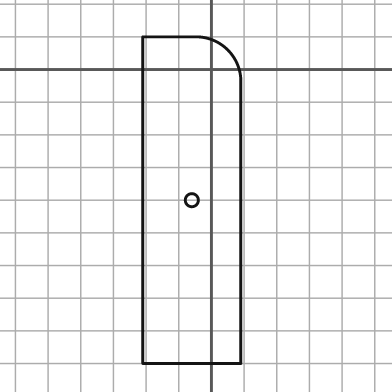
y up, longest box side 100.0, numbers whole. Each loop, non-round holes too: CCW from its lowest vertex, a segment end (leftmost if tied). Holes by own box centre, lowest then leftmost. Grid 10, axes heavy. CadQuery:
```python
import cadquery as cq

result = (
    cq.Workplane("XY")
    .moveTo(-21.0, -90.0)
    .lineTo(9.0, -90.0)
    .lineTo(9.0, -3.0)
    .threePointArc((5.0, 6.0), (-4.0, 10.0))
    .lineTo(-21.0, 10.0)
    .close()
    .moveTo(-6.0, -40.0)
    .circle(2.0)
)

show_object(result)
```